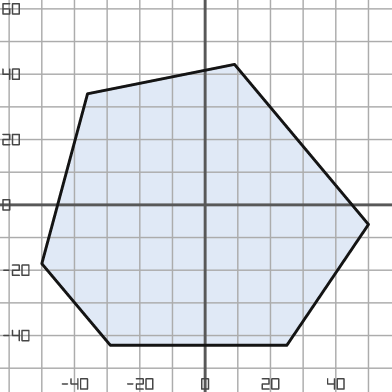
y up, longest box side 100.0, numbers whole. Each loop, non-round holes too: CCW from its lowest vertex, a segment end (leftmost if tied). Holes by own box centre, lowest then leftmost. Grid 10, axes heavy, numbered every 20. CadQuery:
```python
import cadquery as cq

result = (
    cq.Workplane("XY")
    .moveTo(-29.0, -43.0)
    .lineTo(25.0, -43.0)
    .lineTo(50.0, -6.0)
    .lineTo(9.0, 43.0)
    .lineTo(-36.0, 34.0)
    .lineTo(-50.0, -18.0)
    .close()
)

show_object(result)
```